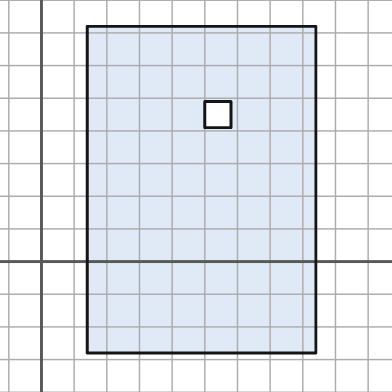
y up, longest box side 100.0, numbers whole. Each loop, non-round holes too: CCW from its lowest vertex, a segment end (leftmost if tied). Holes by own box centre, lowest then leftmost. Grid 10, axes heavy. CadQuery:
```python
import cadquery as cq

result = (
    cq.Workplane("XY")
    .moveTo(14.0, -28.0)
    .lineTo(84.0, -28.0)
    .lineTo(84.0, 72.0)
    .lineTo(14.0, 72.0)
    .close()
    .moveTo(50.0, 41.0)
    .lineTo(58.0, 41.0)
    .lineTo(58.0, 49.0)
    .lineTo(50.0, 49.0)
    .close()
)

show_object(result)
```